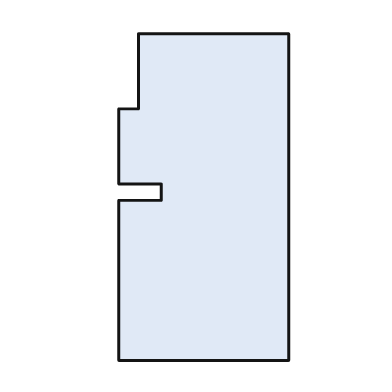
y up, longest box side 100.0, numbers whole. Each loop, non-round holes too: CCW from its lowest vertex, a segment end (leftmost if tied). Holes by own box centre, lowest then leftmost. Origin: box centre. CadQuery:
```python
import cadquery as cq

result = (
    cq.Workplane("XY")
    .moveTo(-26.0, -50.0)
    .lineTo(26.0, -50.0)
    .lineTo(26.0, 50.0)
    .lineTo(-20.0, 50.0)
    .lineTo(-20.0, 27.0)
    .lineTo(-26.0, 27.0)
    .lineTo(-26.0, 4.0)
    .lineTo(-13.0, 4.0)
    .lineTo(-13.0, -1.0)
    .lineTo(-26.0, -1.0)
    .close()
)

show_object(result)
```